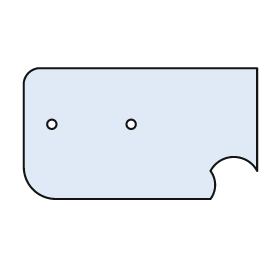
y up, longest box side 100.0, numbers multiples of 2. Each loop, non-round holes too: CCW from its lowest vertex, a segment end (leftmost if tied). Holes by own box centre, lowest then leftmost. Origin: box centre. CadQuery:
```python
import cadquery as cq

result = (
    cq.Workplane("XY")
    .moveTo(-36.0, -28.0)
    .lineTo(30.0, -28.0)
    .threePointArc((32.0, -22.0), (30.0, -16.0))
    .threePointArc((40.0, -10.0), (50.0, -16.0))
    .lineTo(50.0, 28.0)
    .lineTo(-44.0, 28.0)
    .threePointArc((-48.0, 26.0), (-50.0, 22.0))
    .lineTo(-50.0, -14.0)
    .threePointArc((-46.0, -24.0), (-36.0, -28.0))
    .close()
    .moveTo(-38.0, 4.0)
    .circle(2.0)
    .moveTo(-4.0, 4.0)
    .circle(2.0)
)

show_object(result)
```